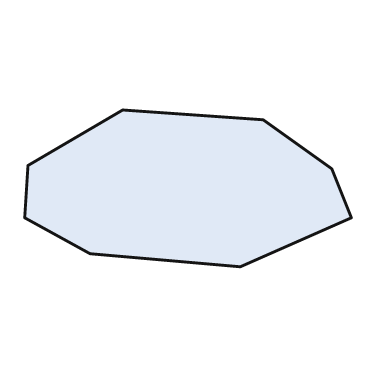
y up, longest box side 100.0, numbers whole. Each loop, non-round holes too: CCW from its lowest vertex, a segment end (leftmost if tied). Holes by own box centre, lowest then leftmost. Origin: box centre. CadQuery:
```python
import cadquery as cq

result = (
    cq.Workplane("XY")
    .moveTo(16.0, -24.0)
    .lineTo(50.0, -9.0)
    .lineTo(44.0, 6.0)
    .lineTo(23.0, 21.0)
    .lineTo(-20.0, 24.0)
    .lineTo(-49.0, 7.0)
    .lineTo(-50.0, -9.0)
    .lineTo(-30.0, -20.0)
    .close()
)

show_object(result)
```